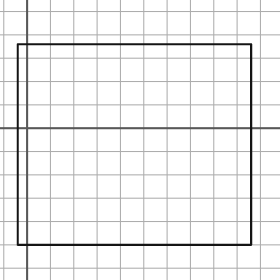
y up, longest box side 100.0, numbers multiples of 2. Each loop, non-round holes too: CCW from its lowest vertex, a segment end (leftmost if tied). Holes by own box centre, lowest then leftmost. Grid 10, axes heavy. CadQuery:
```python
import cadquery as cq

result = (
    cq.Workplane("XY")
    .moveTo(-4.0, -50.0)
    .lineTo(96.0, -50.0)
    .lineTo(96.0, 36.0)
    .lineTo(-4.0, 36.0)
    .close()
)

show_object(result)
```